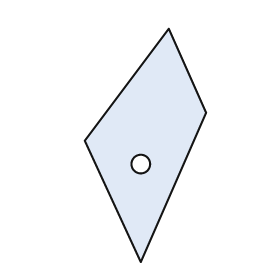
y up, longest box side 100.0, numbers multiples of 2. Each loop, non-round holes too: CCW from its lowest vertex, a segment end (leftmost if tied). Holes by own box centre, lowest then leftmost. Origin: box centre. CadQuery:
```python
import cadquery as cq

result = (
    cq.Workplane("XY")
    .moveTo(-2.0, -50.0)
    .lineTo(26.0, 14.0)
    .lineTo(10.0, 50.0)
    .lineTo(-26.0, 2.0)
    .close()
    .moveTo(-2.0, -8.0)
    .circle(4.0)
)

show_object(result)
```